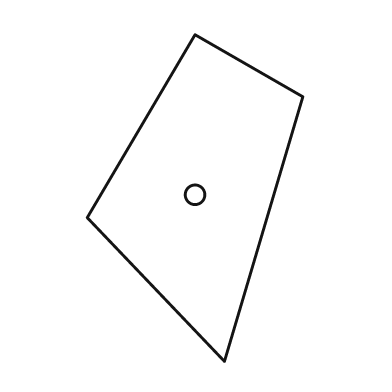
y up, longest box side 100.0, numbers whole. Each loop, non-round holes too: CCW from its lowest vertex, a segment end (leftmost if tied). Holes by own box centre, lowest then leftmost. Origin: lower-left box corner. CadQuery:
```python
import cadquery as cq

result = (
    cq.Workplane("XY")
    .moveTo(42.0, 0.0)
    .lineTo(66.0, 81.0)
    .lineTo(33.0, 100.0)
    .lineTo(0.0, 44.0)
    .close()
    .moveTo(33.0, 51.0)
    .circle(3.0)
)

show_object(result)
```